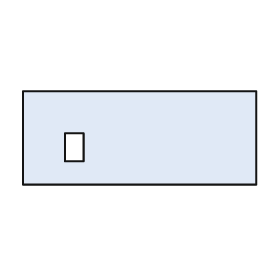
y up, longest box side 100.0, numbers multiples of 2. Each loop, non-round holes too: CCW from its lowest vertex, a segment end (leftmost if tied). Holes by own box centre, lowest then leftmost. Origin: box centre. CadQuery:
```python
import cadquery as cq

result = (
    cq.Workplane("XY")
    .moveTo(-50.0, -20.0)
    .lineTo(50.0, -20.0)
    .lineTo(50.0, 20.0)
    .lineTo(-50.0, 20.0)
    .close()
    .moveTo(-32.0, -10.0)
    .lineTo(-24.0, -10.0)
    .lineTo(-24.0, 2.0)
    .lineTo(-32.0, 2.0)
    .close()
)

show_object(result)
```